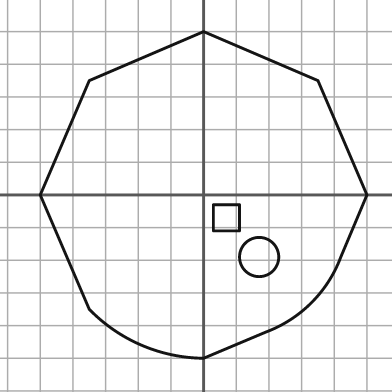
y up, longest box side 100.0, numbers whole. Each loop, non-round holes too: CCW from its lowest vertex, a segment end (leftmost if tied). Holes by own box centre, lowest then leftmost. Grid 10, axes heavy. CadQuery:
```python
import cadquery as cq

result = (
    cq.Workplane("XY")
    .moveTo(0.0, -50.0)
    .lineTo(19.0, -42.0)
    .threePointArc((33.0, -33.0), (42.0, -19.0))
    .lineTo(50.0, 0.0)
    .lineTo(35.0, 35.0)
    .lineTo(0.0, 50.0)
    .lineTo(-35.0, 35.0)
    .lineTo(-50.0, 0.0)
    .lineTo(-35.0, -35.0)
    .threePointArc((-19.0, -46.0), (0.0, -50.0))
    .close()
    .moveTo(17.0, -19.0)
    .circle(6.0)
    .moveTo(3.0, -11.0)
    .lineTo(11.0, -11.0)
    .lineTo(11.0, -3.0)
    .lineTo(3.0, -3.0)
    .close()
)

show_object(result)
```